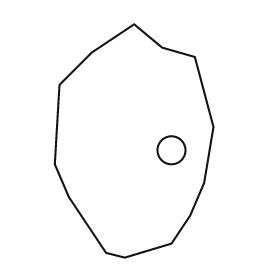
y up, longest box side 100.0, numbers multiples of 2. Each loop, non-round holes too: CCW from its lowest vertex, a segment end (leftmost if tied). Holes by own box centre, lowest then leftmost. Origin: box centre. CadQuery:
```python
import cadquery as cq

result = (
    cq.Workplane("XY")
    .moveTo(-4.0, -50.0)
    .lineTo(16.0, -44.0)
    .lineTo(24.0, -32.0)
    .lineTo(30.0, -18.0)
    .lineTo(34.0, 6.0)
    .lineTo(26.0, 36.0)
    .lineTo(12.0, 40.0)
    .lineTo(0.0, 50.0)
    .lineTo(-18.0, 38.0)
    .lineTo(-32.0, 24.0)
    .lineTo(-34.0, -10.0)
    .lineTo(-28.0, -24.0)
    .lineTo(-12.0, -48.0)
    .close()
    .moveTo(16.0, -4.0)
    .circle(6.0)
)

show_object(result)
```